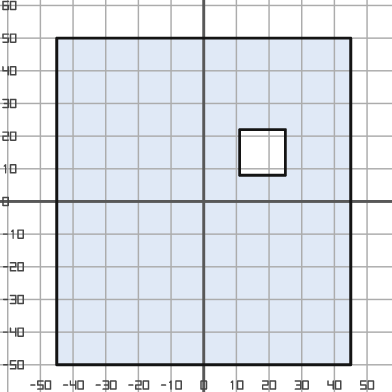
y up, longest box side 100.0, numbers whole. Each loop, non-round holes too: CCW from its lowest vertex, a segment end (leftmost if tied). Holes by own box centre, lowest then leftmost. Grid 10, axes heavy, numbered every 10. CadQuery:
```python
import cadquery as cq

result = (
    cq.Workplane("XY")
    .moveTo(-45.0, -50.0)
    .lineTo(45.0, -50.0)
    .lineTo(45.0, 50.0)
    .lineTo(-45.0, 50.0)
    .close()
    .moveTo(11.0, 8.0)
    .lineTo(25.0, 8.0)
    .lineTo(25.0, 22.0)
    .lineTo(11.0, 22.0)
    .close()
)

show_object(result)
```